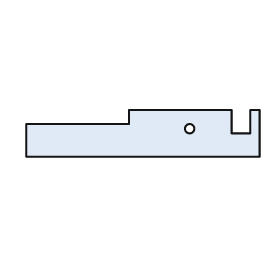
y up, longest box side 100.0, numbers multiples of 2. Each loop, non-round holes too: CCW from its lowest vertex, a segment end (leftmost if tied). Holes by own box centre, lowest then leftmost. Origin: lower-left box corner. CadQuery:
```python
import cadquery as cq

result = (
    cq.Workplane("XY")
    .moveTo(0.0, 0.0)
    .lineTo(100.0, 0.0)
    .lineTo(100.0, 20.0)
    .lineTo(96.0, 20.0)
    .lineTo(96.0, 10.0)
    .lineTo(88.0, 10.0)
    .lineTo(88.0, 20.0)
    .lineTo(44.0, 20.0)
    .lineTo(44.0, 14.0)
    .lineTo(0.0, 14.0)
    .close()
    .moveTo(70.0, 12.0)
    .circle(2.0)
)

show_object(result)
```